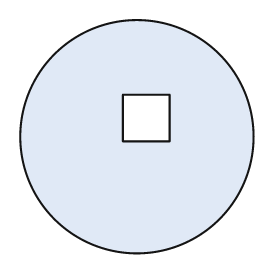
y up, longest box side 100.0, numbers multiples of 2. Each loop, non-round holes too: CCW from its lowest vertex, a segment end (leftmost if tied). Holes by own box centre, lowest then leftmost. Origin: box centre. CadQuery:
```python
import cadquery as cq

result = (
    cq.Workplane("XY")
    .moveTo(0.0, 0.0)
    .circle(50.0)
    .moveTo(-6.0, -2.0)
    .lineTo(14.0, -2.0)
    .lineTo(14.0, 18.0)
    .lineTo(-6.0, 18.0)
    .close()
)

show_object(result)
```